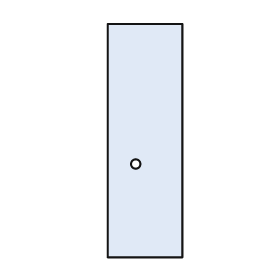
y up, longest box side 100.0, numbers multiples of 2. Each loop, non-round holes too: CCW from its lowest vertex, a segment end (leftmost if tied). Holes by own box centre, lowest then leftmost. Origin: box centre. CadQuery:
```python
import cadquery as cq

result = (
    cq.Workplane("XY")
    .moveTo(-16.0, -50.0)
    .lineTo(16.0, -50.0)
    .lineTo(16.0, 50.0)
    .lineTo(-16.0, 50.0)
    .close()
    .moveTo(-4.0, -10.0)
    .circle(2.0)
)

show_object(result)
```